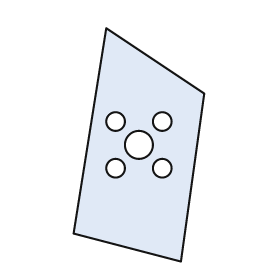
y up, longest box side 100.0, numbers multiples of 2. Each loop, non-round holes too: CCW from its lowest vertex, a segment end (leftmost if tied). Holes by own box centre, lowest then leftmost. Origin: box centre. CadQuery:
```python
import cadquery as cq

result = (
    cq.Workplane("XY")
    .moveTo(18.0, -50.0)
    .lineTo(28.0, 22.0)
    .lineTo(-14.0, 50.0)
    .lineTo(-28.0, -38.0)
    .close()
    .moveTo(-10.0, -10.0)
    .circle(4.0)
    .moveTo(10.0, -10.0)
    .circle(4.0)
    .moveTo(0.0, 0.0)
    .circle(6.0)
    .moveTo(-10.0, 10.0)
    .circle(4.0)
    .moveTo(10.0, 10.0)
    .circle(4.0)
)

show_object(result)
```